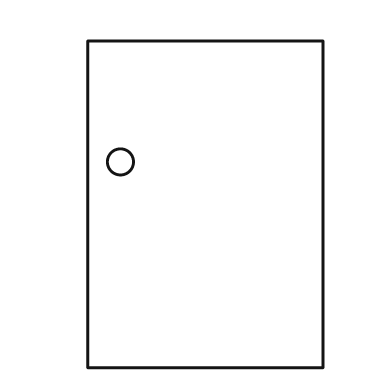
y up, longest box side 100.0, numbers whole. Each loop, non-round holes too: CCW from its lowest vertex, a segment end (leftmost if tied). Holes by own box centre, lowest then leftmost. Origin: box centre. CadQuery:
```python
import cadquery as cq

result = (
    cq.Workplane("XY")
    .moveTo(-36.0, -50.0)
    .lineTo(36.0, -50.0)
    .lineTo(36.0, 50.0)
    .lineTo(-36.0, 50.0)
    .close()
    .moveTo(-26.0, 13.0)
    .circle(4.0)
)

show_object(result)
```